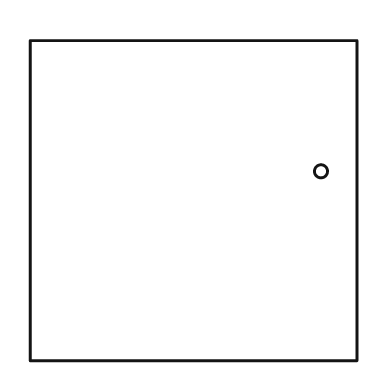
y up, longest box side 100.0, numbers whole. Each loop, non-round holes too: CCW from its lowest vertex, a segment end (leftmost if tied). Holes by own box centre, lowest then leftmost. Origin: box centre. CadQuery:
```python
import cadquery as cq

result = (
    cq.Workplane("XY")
    .moveTo(-50.0, -49.0)
    .lineTo(50.0, -49.0)
    .lineTo(50.0, 49.0)
    .lineTo(-50.0, 49.0)
    .close()
    .moveTo(39.0, 9.0)
    .circle(2.0)
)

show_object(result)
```